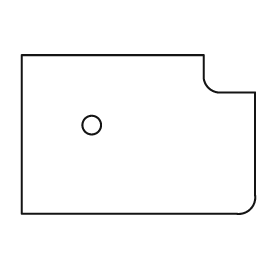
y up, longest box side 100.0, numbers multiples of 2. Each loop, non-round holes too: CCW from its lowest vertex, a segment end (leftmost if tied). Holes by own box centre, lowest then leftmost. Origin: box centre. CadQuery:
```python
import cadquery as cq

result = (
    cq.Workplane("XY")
    .moveTo(-50.0, -34.0)
    .lineTo(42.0, -34.0)
    .threePointArc((48.0, -32.0), (50.0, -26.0))
    .lineTo(50.0, 18.0)
    .lineTo(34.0, 18.0)
    .threePointArc((30.0, 20.0), (28.0, 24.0))
    .lineTo(28.0, 34.0)
    .lineTo(-50.0, 34.0)
    .close()
    .moveTo(-20.0, 4.0)
    .circle(4.0)
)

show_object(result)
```